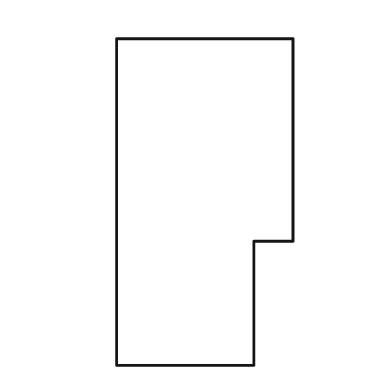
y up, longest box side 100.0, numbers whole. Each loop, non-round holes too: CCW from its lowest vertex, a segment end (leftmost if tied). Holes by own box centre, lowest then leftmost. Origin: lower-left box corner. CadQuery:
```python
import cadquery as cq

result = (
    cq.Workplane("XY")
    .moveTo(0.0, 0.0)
    .lineTo(42.0, 0.0)
    .lineTo(42.0, 38.0)
    .lineTo(54.0, 38.0)
    .lineTo(54.0, 100.0)
    .lineTo(0.0, 100.0)
    .close()
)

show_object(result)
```